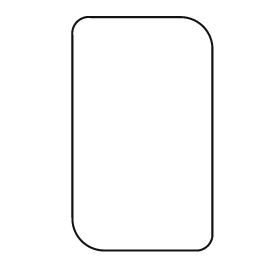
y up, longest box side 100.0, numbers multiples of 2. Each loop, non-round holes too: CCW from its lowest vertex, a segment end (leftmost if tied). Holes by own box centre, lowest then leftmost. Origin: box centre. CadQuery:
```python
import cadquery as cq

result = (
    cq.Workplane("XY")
    .moveTo(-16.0, -50.0)
    .lineTo(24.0, -50.0)
    .threePointArc((28.0, -48.0), (30.0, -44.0))
    .lineTo(30.0, 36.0)
    .threePointArc((26.0, 46.0), (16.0, 50.0))
    .lineTo(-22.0, 50.0)
    .threePointArc((-28.0, 48.0), (-30.0, 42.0))
    .lineTo(-30.0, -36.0)
    .threePointArc((-26.0, -46.0), (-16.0, -50.0))
    .close()
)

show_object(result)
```